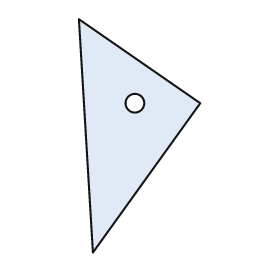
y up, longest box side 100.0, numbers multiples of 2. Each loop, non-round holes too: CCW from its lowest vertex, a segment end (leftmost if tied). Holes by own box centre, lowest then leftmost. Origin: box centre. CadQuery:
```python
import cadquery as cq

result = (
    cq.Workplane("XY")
    .moveTo(-20.0, -50.0)
    .lineTo(26.0, 14.0)
    .lineTo(-26.0, 50.0)
    .close()
    .moveTo(-2.0, 14.0)
    .circle(4.0)
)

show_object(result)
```